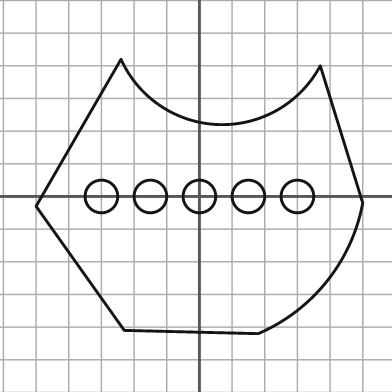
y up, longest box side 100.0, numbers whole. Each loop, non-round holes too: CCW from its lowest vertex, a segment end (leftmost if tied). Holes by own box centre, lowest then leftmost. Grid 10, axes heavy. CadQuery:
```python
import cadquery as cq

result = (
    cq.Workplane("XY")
    .moveTo(18.0, -42.0)
    .threePointArc((39.0, -26.0), (50.0, -2.0))
    .lineTo(37.0, 40.0)
    .threePointArc((6.0, 22.0), (-24.0, 42.0))
    .lineTo(-50.0, -3.0)
    .lineTo(-23.0, -41.0)
    .close()
    .moveTo(-30.0, 0.0)
    .circle(5.0)
    .moveTo(-15.0, 0.0)
    .circle(5.0)
    .moveTo(0.0, 0.0)
    .circle(5.0)
    .moveTo(15.0, 0.0)
    .circle(5.0)
    .moveTo(30.0, 0.0)
    .circle(5.0)
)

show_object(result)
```